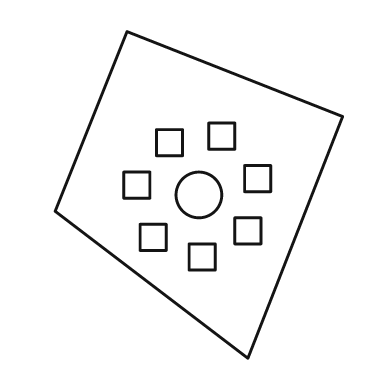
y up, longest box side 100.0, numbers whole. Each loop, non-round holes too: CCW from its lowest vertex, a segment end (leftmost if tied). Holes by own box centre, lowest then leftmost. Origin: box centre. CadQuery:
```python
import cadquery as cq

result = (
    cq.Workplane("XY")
    .moveTo(15.0, -50.0)
    .lineTo(44.0, 24.0)
    .lineTo(-22.0, 50.0)
    .lineTo(-44.0, -5.0)
    .close()
    .moveTo(-3.0, -23.0)
    .lineTo(5.0, -23.0)
    .lineTo(5.0, -15.0)
    .lineTo(-3.0, -15.0)
    .close()
    .moveTo(-18.0, -17.0)
    .lineTo(-10.0, -17.0)
    .lineTo(-10.0, -9.0)
    .lineTo(-18.0, -9.0)
    .close()
    .moveTo(11.0, -15.0)
    .lineTo(19.0, -15.0)
    .lineTo(19.0, -7.0)
    .lineTo(11.0, -7.0)
    .close()
    .moveTo(0.0, 0.0)
    .circle(7.0)
    .moveTo(-23.0, -1.0)
    .lineTo(-15.0, -1.0)
    .lineTo(-15.0, 7.0)
    .lineTo(-23.0, 7.0)
    .close()
    .moveTo(14.0, 1.0)
    .lineTo(22.0, 1.0)
    .lineTo(22.0, 9.0)
    .lineTo(14.0, 9.0)
    .close()
    .moveTo(-13.0, 12.0)
    .lineTo(-5.0, 12.0)
    .lineTo(-5.0, 20.0)
    .lineTo(-13.0, 20.0)
    .close()
    .moveTo(3.0, 14.0)
    .lineTo(11.0, 14.0)
    .lineTo(11.0, 22.0)
    .lineTo(3.0, 22.0)
    .close()
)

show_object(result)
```